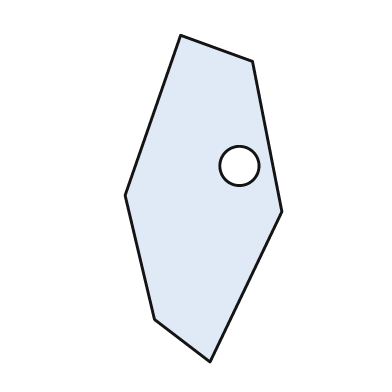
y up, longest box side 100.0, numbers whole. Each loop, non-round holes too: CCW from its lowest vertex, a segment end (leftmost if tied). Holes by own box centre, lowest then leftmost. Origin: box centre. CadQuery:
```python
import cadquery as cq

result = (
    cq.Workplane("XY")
    .moveTo(2.0, -50.0)
    .lineTo(24.0, -4.0)
    .lineTo(15.0, 42.0)
    .lineTo(-7.0, 50.0)
    .lineTo(-24.0, 1.0)
    .lineTo(-15.0, -37.0)
    .close()
    .moveTo(11.0, 10.0)
    .circle(6.0)
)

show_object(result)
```